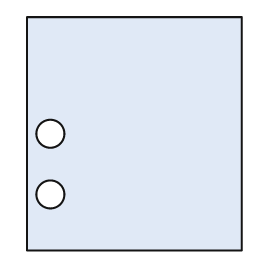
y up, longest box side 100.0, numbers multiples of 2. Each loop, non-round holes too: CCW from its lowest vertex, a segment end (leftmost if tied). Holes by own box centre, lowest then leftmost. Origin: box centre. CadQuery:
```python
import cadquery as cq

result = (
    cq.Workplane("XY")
    .moveTo(-46.0, -50.0)
    .lineTo(46.0, -50.0)
    .lineTo(46.0, 50.0)
    .lineTo(-46.0, 50.0)
    .close()
    .moveTo(-36.0, -26.0)
    .circle(6.0)
    .moveTo(-36.0, 0.0)
    .circle(6.0)
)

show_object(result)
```